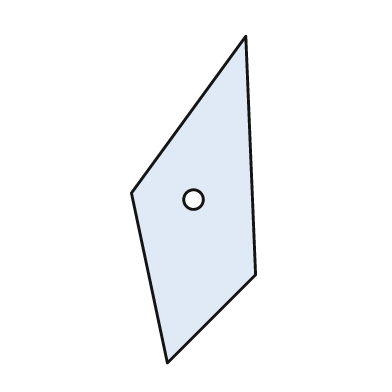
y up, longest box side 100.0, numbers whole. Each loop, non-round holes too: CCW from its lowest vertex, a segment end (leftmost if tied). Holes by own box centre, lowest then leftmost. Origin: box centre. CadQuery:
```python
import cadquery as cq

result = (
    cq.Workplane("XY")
    .moveTo(-8.0, -50.0)
    .lineTo(19.0, -23.0)
    .lineTo(16.0, 50.0)
    .lineTo(-19.0, 2.0)
    .close()
    .moveTo(0.0, 0.0)
    .circle(3.0)
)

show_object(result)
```